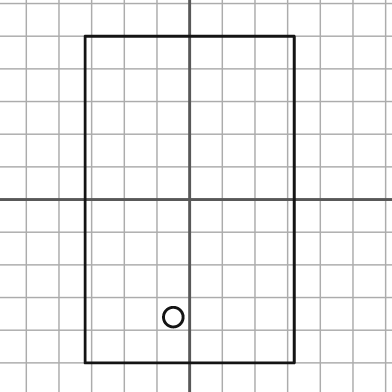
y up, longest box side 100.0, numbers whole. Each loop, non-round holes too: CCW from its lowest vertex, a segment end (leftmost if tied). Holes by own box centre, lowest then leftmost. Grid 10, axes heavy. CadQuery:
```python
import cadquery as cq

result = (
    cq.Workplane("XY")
    .moveTo(-32.0, -50.0)
    .lineTo(32.0, -50.0)
    .lineTo(32.0, 50.0)
    .lineTo(-32.0, 50.0)
    .close()
    .moveTo(-5.0, -36.0)
    .circle(3.0)
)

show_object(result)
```